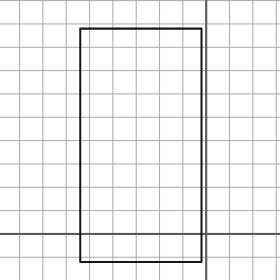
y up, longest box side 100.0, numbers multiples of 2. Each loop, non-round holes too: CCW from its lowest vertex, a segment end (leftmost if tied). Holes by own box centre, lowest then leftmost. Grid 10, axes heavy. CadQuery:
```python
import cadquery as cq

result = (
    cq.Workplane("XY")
    .moveTo(-54.0, -12.0)
    .lineTo(-2.0, -12.0)
    .lineTo(-2.0, 88.0)
    .lineTo(-54.0, 88.0)
    .close()
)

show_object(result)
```